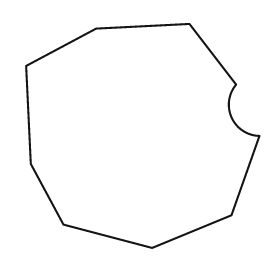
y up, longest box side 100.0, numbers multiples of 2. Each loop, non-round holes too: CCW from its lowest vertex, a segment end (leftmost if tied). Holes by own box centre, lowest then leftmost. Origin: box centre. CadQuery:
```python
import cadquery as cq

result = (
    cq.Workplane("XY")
    .moveTo(4.0, -48.0)
    .lineTo(38.0, -34.0)
    .lineTo(50.0, 0.0)
    .threePointArc((38.0, 8.0), (40.0, 22.0))
    .lineTo(20.0, 48.0)
    .lineTo(-20.0, 46.0)
    .lineTo(-50.0, 30.0)
    .lineTo(-48.0, -12.0)
    .lineTo(-34.0, -38.0)
    .close()
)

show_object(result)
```